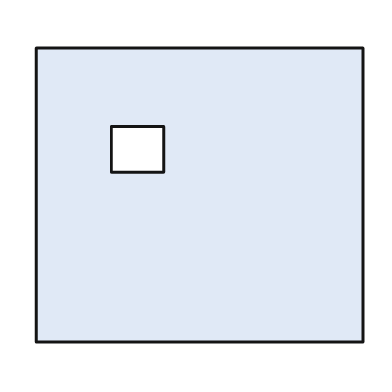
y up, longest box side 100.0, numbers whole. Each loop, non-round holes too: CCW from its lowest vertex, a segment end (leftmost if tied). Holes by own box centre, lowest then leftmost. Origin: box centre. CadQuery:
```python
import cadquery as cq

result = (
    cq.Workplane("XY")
    .moveTo(-50.0, -45.0)
    .lineTo(50.0, -45.0)
    .lineTo(50.0, 45.0)
    .lineTo(-50.0, 45.0)
    .close()
    .moveTo(-27.0, 7.0)
    .lineTo(-11.0, 7.0)
    .lineTo(-11.0, 21.0)
    .lineTo(-27.0, 21.0)
    .close()
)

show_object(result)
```